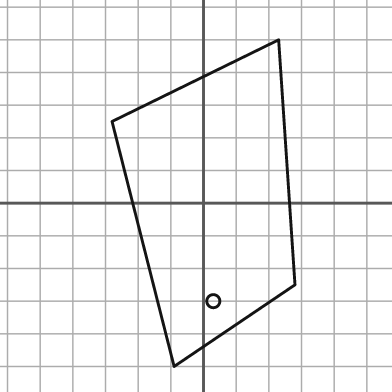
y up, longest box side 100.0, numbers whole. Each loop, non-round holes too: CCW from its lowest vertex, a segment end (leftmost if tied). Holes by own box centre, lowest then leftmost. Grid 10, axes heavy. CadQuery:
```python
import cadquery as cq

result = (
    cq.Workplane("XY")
    .moveTo(-9.0, -50.0)
    .lineTo(28.0, -25.0)
    .lineTo(23.0, 50.0)
    .lineTo(-28.0, 25.0)
    .close()
    .moveTo(3.0, -30.0)
    .circle(2.0)
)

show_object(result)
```